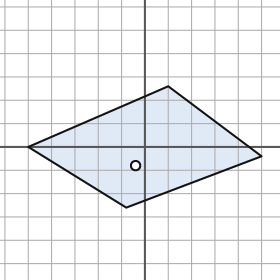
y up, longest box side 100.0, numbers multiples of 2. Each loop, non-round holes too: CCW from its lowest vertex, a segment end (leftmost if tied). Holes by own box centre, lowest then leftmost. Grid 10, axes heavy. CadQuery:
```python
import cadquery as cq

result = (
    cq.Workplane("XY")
    .moveTo(-8.0, -26.0)
    .lineTo(50.0, -4.0)
    .lineTo(10.0, 26.0)
    .lineTo(-50.0, 0.0)
    .close()
    .moveTo(-4.0, -8.0)
    .circle(2.0)
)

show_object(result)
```